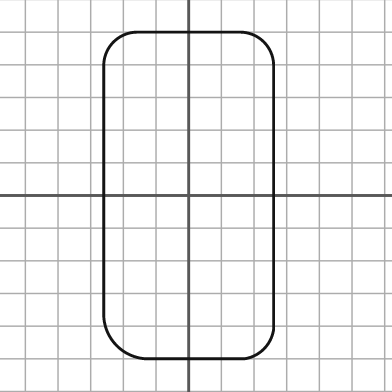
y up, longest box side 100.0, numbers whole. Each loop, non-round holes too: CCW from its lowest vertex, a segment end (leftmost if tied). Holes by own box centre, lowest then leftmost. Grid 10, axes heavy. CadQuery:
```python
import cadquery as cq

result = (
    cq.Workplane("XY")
    .moveTo(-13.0, -50.0)
    .lineTo(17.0, -50.0)
    .threePointArc((23.0, -47.0), (26.0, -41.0))
    .lineTo(26.0, 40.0)
    .threePointArc((23.0, 47.0), (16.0, 50.0))
    .lineTo(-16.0, 50.0)
    .threePointArc((-23.0, 47.0), (-26.0, 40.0))
    .lineTo(-26.0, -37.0)
    .threePointArc((-22.0, -46.0), (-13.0, -50.0))
    .close()
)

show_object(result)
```